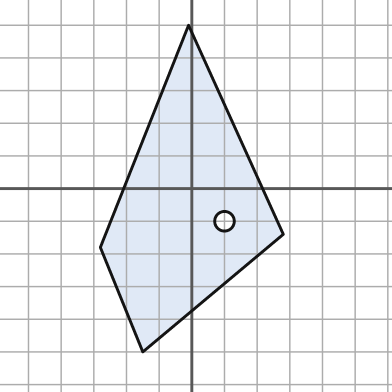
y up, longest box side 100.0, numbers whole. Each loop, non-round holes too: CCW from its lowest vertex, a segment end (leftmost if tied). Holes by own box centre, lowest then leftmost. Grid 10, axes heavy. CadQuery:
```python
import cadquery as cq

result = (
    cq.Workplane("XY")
    .moveTo(-15.0, -50.0)
    .lineTo(28.0, -14.0)
    .lineTo(-1.0, 50.0)
    .lineTo(-28.0, -18.0)
    .close()
    .moveTo(10.0, -10.0)
    .circle(3.0)
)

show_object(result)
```